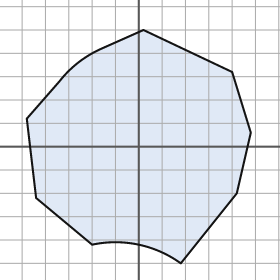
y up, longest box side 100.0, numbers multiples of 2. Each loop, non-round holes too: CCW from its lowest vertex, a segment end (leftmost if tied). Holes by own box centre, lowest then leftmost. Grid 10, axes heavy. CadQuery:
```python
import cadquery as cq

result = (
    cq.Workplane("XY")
    .moveTo(18.0, -50.0)
    .lineTo(42.0, -20.0)
    .lineTo(48.0, 6.0)
    .lineTo(40.0, 32.0)
    .lineTo(2.0, 50.0)
    .lineTo(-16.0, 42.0)
    .threePointArc((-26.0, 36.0), (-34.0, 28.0))
    .lineTo(-48.0, 12.0)
    .lineTo(-44.0, -22.0)
    .lineTo(-20.0, -42.0)
    .threePointArc((0.0, -42.0), (18.0, -50.0))
    .close()
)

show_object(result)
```